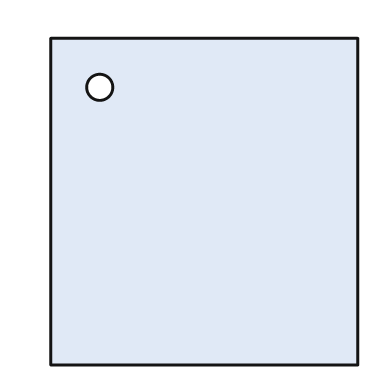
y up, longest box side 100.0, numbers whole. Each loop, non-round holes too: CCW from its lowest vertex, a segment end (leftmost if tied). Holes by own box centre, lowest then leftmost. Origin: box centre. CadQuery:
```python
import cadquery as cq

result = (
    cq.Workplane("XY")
    .moveTo(-47.0, -50.0)
    .lineTo(47.0, -50.0)
    .lineTo(47.0, 50.0)
    .lineTo(-47.0, 50.0)
    .close()
    .moveTo(-32.0, 35.0)
    .circle(4.0)
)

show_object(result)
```